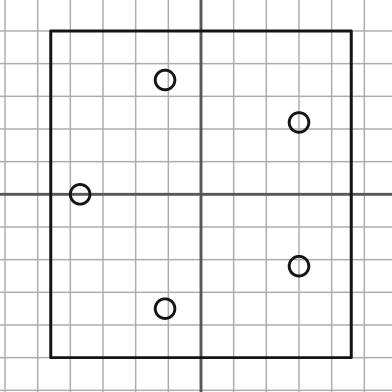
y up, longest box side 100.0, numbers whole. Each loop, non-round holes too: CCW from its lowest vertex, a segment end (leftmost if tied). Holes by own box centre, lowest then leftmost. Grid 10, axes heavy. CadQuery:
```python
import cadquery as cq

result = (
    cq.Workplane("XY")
    .moveTo(-46.0, -50.0)
    .lineTo(46.0, -50.0)
    .lineTo(46.0, 50.0)
    .lineTo(-46.0, 50.0)
    .close()
    .moveTo(-11.0, -35.0)
    .circle(3.0)
    .moveTo(30.0, -22.0)
    .circle(3.0)
    .moveTo(-37.0, 0.0)
    .circle(3.0)
    .moveTo(30.0, 22.0)
    .circle(3.0)
    .moveTo(-11.0, 35.0)
    .circle(3.0)
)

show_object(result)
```